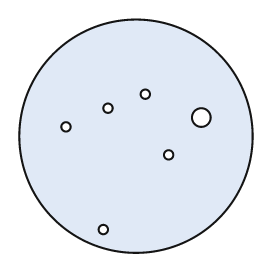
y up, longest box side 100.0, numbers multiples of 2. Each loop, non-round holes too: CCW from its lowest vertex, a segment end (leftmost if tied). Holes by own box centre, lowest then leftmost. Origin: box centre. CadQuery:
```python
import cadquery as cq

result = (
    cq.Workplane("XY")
    .moveTo(0.0, 0.0)
    .circle(50.0)
    .moveTo(-14.0, -40.0)
    .circle(2.0)
    .moveTo(14.0, -8.0)
    .circle(2.0)
    .moveTo(-30.0, 4.0)
    .circle(2.0)
    .moveTo(28.0, 8.0)
    .circle(4.0)
    .moveTo(-12.0, 12.0)
    .circle(2.0)
    .moveTo(4.0, 18.0)
    .circle(2.0)
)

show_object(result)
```